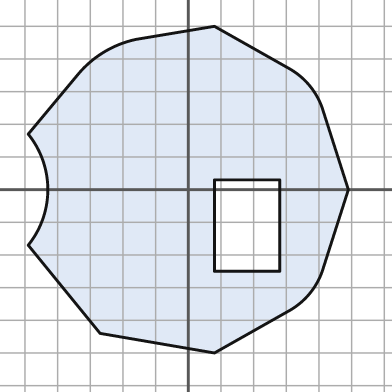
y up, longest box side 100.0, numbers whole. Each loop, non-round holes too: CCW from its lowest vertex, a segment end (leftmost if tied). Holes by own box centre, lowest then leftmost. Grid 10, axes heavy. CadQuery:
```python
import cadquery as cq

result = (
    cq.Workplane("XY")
    .moveTo(8.0, -50.0)
    .lineTo(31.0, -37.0)
    .threePointArc((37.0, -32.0), (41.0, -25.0))
    .lineTo(49.0, 0.0)
    .lineTo(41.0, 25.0)
    .threePointArc((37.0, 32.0), (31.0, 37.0))
    .lineTo(8.0, 50.0)
    .lineTo(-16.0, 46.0)
    .threePointArc((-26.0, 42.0), (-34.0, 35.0))
    .lineTo(-49.0, 17.0)
    .threePointArc((-43.0, 0.0), (-49.0, -17.0))
    .lineTo(-27.0, -44.0)
    .close()
    .moveTo(8.0, -25.0)
    .lineTo(28.0, -25.0)
    .lineTo(28.0, 3.0)
    .lineTo(8.0, 3.0)
    .close()
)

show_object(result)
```